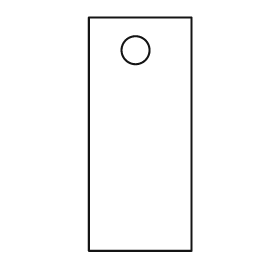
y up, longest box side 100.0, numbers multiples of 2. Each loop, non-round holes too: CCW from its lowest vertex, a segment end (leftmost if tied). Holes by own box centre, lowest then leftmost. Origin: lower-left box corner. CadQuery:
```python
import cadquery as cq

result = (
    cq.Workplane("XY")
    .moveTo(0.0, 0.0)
    .lineTo(44.0, 0.0)
    .lineTo(44.0, 100.0)
    .lineTo(0.0, 100.0)
    .close()
    .moveTo(20.0, 86.0)
    .circle(6.0)
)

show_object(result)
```